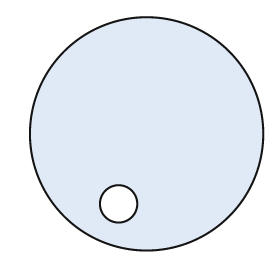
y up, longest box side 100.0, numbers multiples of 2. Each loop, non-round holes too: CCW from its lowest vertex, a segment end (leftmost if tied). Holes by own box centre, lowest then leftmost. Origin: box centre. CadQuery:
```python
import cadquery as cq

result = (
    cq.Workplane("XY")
    .moveTo(0.0, 0.0)
    .circle(50.0)
    .moveTo(-12.0, -30.0)
    .circle(8.0)
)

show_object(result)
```